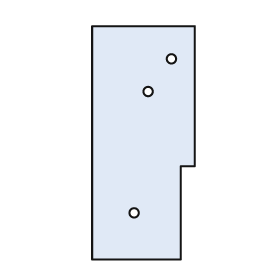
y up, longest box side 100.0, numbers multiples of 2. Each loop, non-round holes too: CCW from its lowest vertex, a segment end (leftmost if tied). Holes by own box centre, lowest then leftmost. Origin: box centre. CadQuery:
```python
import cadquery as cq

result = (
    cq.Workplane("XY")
    .moveTo(-22.0, -50.0)
    .lineTo(16.0, -50.0)
    .lineTo(16.0, -10.0)
    .lineTo(22.0, -10.0)
    .lineTo(22.0, 50.0)
    .lineTo(-22.0, 50.0)
    .close()
    .moveTo(-4.0, -30.0)
    .circle(2.0)
    .moveTo(2.0, 22.0)
    .circle(2.0)
    .moveTo(12.0, 36.0)
    .circle(2.0)
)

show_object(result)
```